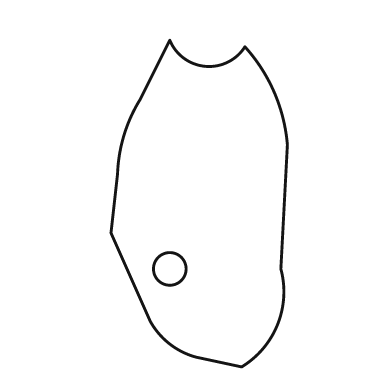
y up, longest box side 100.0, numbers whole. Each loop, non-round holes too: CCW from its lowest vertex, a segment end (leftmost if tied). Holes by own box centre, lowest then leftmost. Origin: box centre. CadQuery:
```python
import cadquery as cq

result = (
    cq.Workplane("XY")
    .moveTo(13.0, -50.0)
    .threePointArc((24.0, -37.0), (25.0, -20.0))
    .lineTo(27.0, 18.0)
    .threePointArc((23.0, 34.0), (14.0, 48.0))
    .threePointArc((2.0, 42.0), (-9.0, 50.0))
    .lineTo(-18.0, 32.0)
    .threePointArc((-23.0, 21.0), (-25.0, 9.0))
    .lineTo(-27.0, -9.0)
    .lineTo(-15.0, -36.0)
    .threePointArc((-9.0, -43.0), (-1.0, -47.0))
    .close()
    .moveTo(-9.0, -20.0)
    .circle(5.0)
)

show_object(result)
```